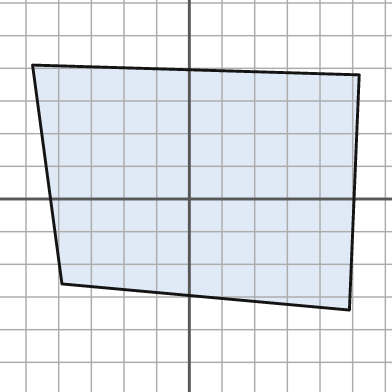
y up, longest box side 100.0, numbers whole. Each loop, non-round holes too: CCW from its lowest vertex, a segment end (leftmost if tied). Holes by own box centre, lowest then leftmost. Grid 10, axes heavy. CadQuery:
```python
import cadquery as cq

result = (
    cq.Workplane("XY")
    .moveTo(49.0, -34.0)
    .lineTo(52.0, 38.0)
    .lineTo(-48.0, 41.0)
    .lineTo(-39.0, -26.0)
    .close()
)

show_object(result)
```